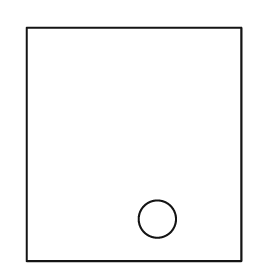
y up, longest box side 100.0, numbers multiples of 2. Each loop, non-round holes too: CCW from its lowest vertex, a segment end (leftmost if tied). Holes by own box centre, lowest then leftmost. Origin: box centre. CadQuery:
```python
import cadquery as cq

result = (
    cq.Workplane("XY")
    .moveTo(-46.0, -50.0)
    .lineTo(46.0, -50.0)
    .lineTo(46.0, 50.0)
    .lineTo(-46.0, 50.0)
    .close()
    .moveTo(10.0, -32.0)
    .circle(8.0)
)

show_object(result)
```